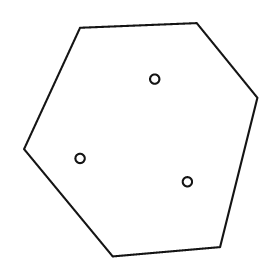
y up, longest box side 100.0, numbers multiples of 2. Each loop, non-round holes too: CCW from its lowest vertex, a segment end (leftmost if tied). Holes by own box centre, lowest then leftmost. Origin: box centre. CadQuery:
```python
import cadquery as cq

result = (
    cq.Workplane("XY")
    .moveTo(-12.0, -50.0)
    .lineTo(34.0, -46.0)
    .lineTo(50.0, 18.0)
    .lineTo(24.0, 50.0)
    .lineTo(-26.0, 48.0)
    .lineTo(-50.0, -4.0)
    .close()
    .moveTo(20.0, -18.0)
    .circle(2.0)
    .moveTo(-26.0, -8.0)
    .circle(2.0)
    .moveTo(6.0, 26.0)
    .circle(2.0)
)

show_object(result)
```